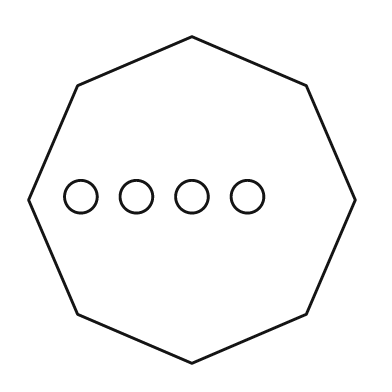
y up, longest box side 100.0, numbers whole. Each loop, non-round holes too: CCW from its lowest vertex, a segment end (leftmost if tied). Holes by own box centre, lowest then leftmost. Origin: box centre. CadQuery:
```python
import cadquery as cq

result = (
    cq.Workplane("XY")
    .moveTo(0.0, -50.0)
    .lineTo(35.0, -35.0)
    .lineTo(50.0, 0.0)
    .lineTo(35.0, 35.0)
    .lineTo(0.0, 50.0)
    .lineTo(-35.0, 35.0)
    .lineTo(-50.0, 0.0)
    .lineTo(-35.0, -35.0)
    .close()
    .moveTo(-34.0, 1.0)
    .circle(5.0)
    .moveTo(-17.0, 1.0)
    .circle(5.0)
    .moveTo(0.0, 1.0)
    .circle(5.0)
    .moveTo(17.0, 1.0)
    .circle(5.0)
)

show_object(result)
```